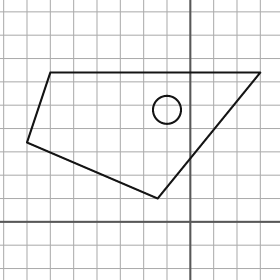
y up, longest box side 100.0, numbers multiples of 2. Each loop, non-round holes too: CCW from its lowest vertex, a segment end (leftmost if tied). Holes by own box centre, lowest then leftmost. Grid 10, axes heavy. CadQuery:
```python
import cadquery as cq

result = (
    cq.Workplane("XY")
    .moveTo(-14.0, 10.0)
    .lineTo(30.0, 64.0)
    .lineTo(-60.0, 64.0)
    .lineTo(-70.0, 34.0)
    .close()
    .moveTo(-10.0, 48.0)
    .circle(6.0)
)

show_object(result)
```